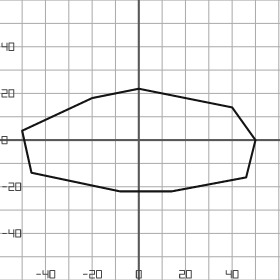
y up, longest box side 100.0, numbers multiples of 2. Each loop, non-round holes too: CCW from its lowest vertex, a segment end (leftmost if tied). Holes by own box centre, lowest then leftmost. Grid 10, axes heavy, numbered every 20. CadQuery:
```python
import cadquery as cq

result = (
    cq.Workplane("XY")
    .moveTo(-8.0, -22.0)
    .lineTo(14.0, -22.0)
    .lineTo(46.0, -16.0)
    .lineTo(50.0, 0.0)
    .lineTo(40.0, 14.0)
    .lineTo(0.0, 22.0)
    .lineTo(-20.0, 18.0)
    .lineTo(-50.0, 4.0)
    .lineTo(-46.0, -14.0)
    .close()
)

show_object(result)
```